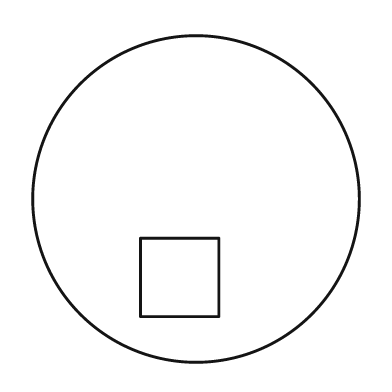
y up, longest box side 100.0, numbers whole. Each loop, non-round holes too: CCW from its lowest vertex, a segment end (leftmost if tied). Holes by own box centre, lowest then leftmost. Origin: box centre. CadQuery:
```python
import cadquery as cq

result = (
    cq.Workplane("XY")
    .moveTo(0.0, 0.0)
    .circle(50.0)
    .moveTo(-17.0, -36.0)
    .lineTo(7.0, -36.0)
    .lineTo(7.0, -12.0)
    .lineTo(-17.0, -12.0)
    .close()
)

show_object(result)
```